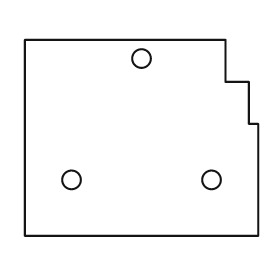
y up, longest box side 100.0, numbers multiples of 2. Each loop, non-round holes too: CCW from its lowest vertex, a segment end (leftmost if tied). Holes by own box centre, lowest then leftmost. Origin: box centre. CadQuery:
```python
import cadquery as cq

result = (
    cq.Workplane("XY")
    .moveTo(-50.0, -42.0)
    .lineTo(50.0, -42.0)
    .lineTo(50.0, 6.0)
    .lineTo(46.0, 6.0)
    .lineTo(46.0, 24.0)
    .lineTo(36.0, 24.0)
    .lineTo(36.0, 42.0)
    .lineTo(-50.0, 42.0)
    .close()
    .moveTo(-30.0, -18.0)
    .circle(4.0)
    .moveTo(30.0, -18.0)
    .circle(4.0)
    .moveTo(0.0, 34.0)
    .circle(4.0)
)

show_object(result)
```